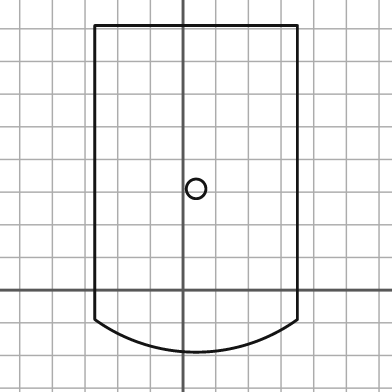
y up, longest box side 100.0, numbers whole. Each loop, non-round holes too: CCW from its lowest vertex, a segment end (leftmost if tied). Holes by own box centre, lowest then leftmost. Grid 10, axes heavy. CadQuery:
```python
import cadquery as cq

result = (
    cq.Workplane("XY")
    .moveTo(-27.0, -9.0)
    .threePointArc((4.0, -19.0), (35.0, -9.0))
    .lineTo(35.0, 81.0)
    .lineTo(-27.0, 81.0)
    .close()
    .moveTo(4.0, 31.0)
    .circle(3.0)
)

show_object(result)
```